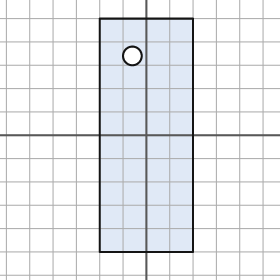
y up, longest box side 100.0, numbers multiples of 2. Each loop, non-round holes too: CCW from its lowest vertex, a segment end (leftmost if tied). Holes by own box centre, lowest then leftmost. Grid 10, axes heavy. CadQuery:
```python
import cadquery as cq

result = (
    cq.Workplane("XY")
    .moveTo(-20.0, -50.0)
    .lineTo(20.0, -50.0)
    .lineTo(20.0, 50.0)
    .lineTo(-20.0, 50.0)
    .close()
    .moveTo(-6.0, 34.0)
    .circle(4.0)
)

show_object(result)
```